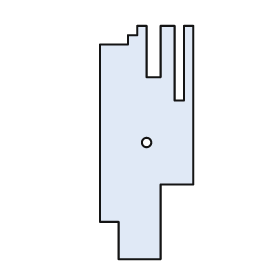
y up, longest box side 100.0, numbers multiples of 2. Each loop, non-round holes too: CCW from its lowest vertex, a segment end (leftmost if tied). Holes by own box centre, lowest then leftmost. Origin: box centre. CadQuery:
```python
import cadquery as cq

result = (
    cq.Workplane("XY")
    .moveTo(-12.0, -50.0)
    .lineTo(6.0, -50.0)
    .lineTo(6.0, -18.0)
    .lineTo(20.0, -18.0)
    .lineTo(20.0, 50.0)
    .lineTo(16.0, 50.0)
    .lineTo(16.0, 18.0)
    .lineTo(12.0, 18.0)
    .lineTo(12.0, 50.0)
    .lineTo(6.0, 50.0)
    .lineTo(6.0, 28.0)
    .lineTo(0.0, 28.0)
    .lineTo(0.0, 50.0)
    .lineTo(-4.0, 50.0)
    .lineTo(-4.0, 46.0)
    .lineTo(-8.0, 46.0)
    .lineTo(-8.0, 42.0)
    .lineTo(-20.0, 42.0)
    .lineTo(-20.0, -34.0)
    .lineTo(-12.0, -34.0)
    .close()
    .moveTo(0.0, 0.0)
    .circle(2.0)
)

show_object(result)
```